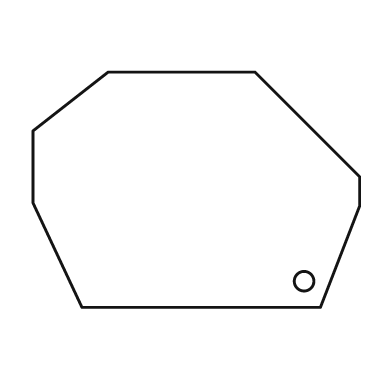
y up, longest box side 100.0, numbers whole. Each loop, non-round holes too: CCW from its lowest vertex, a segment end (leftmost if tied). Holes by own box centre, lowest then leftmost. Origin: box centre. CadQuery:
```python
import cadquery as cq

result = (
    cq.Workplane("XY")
    .moveTo(-35.0, -36.0)
    .lineTo(38.0, -36.0)
    .lineTo(50.0, -5.0)
    .lineTo(50.0, 4.0)
    .lineTo(18.0, 36.0)
    .lineTo(-27.0, 36.0)
    .lineTo(-50.0, 18.0)
    .lineTo(-50.0, -4.0)
    .close()
    .moveTo(33.0, -28.0)
    .circle(3.0)
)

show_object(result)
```